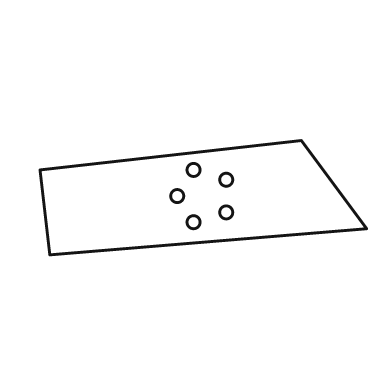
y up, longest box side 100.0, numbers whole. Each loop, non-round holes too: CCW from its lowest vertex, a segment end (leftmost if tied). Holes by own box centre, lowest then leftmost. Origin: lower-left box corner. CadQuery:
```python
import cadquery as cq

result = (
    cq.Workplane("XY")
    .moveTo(3.0, 0.0)
    .lineTo(100.0, 8.0)
    .lineTo(80.0, 35.0)
    .lineTo(0.0, 26.0)
    .close()
    .moveTo(47.0, 10.0)
    .circle(2.0)
    .moveTo(57.0, 13.0)
    .circle(2.0)
    .moveTo(42.0, 18.0)
    .circle(2.0)
    .moveTo(57.0, 23.0)
    .circle(2.0)
    .moveTo(47.0, 26.0)
    .circle(2.0)
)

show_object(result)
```